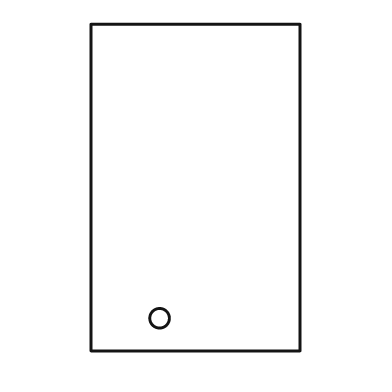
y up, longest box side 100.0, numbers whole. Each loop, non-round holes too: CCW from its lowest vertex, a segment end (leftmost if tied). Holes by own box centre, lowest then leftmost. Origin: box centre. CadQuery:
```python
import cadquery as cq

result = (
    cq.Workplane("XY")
    .moveTo(-32.0, -50.0)
    .lineTo(32.0, -50.0)
    .lineTo(32.0, 50.0)
    .lineTo(-32.0, 50.0)
    .close()
    .moveTo(-11.0, -40.0)
    .circle(3.0)
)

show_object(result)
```